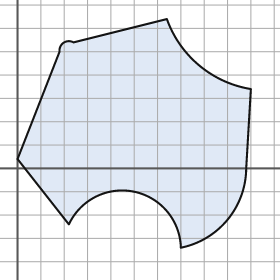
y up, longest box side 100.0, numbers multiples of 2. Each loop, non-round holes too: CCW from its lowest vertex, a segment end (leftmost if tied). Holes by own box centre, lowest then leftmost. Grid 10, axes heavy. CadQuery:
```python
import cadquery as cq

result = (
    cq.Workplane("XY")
    .moveTo(70.0, -34.0)
    .threePointArc((90.0, -22.0), (98.0, 0.0))
    .lineTo(100.0, 34.0)
    .threePointArc((78.0, 44.0), (64.0, 64.0))
    .lineTo(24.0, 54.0)
    .threePointArc((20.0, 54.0), (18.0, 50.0))
    .lineTo(0.0, 4.0)
    .lineTo(22.0, -24.0)
    .threePointArc((50.0, -10.0), (70.0, -34.0))
    .close()
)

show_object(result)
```